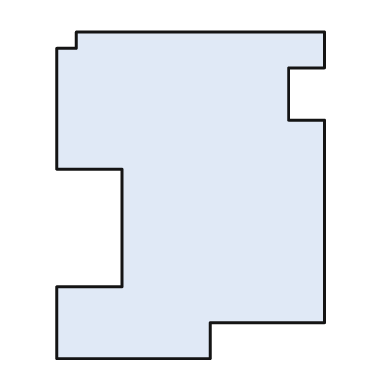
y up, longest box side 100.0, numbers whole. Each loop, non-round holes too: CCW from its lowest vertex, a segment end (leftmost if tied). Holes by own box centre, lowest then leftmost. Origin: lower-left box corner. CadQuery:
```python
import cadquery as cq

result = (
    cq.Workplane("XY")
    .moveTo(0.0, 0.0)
    .lineTo(47.0, 0.0)
    .lineTo(47.0, 11.0)
    .lineTo(82.0, 11.0)
    .lineTo(82.0, 73.0)
    .lineTo(71.0, 73.0)
    .lineTo(71.0, 89.0)
    .lineTo(82.0, 89.0)
    .lineTo(82.0, 100.0)
    .lineTo(6.0, 100.0)
    .lineTo(6.0, 95.0)
    .lineTo(0.0, 95.0)
    .lineTo(0.0, 58.0)
    .lineTo(20.0, 58.0)
    .lineTo(20.0, 22.0)
    .lineTo(0.0, 22.0)
    .close()
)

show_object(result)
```